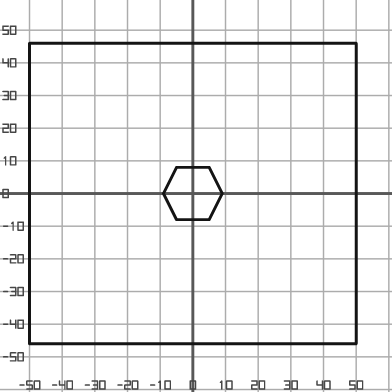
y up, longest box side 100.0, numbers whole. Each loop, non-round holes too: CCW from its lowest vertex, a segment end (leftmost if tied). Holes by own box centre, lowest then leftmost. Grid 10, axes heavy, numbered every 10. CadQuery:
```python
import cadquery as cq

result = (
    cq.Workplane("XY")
    .moveTo(-50.0, -46.0)
    .lineTo(50.0, -46.0)
    .lineTo(50.0, 46.0)
    .lineTo(-50.0, 46.0)
    .close()
    .moveTo(-5.0, -8.0)
    .lineTo(5.0, -8.0)
    .lineTo(9.0, 0.0)
    .lineTo(5.0, 8.0)
    .lineTo(-5.0, 8.0)
    .lineTo(-9.0, 0.0)
    .close()
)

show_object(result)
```